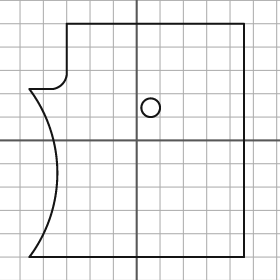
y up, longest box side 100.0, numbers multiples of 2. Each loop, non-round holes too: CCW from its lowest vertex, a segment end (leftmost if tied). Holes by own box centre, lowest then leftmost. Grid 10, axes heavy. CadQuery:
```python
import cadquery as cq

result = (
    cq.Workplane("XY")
    .moveTo(-46.0, -50.0)
    .lineTo(46.0, -50.0)
    .lineTo(46.0, 50.0)
    .lineTo(-30.0, 50.0)
    .lineTo(-30.0, 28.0)
    .threePointArc((-32.0, 24.0), (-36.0, 22.0))
    .lineTo(-46.0, 22.0)
    .threePointArc((-34.0, -14.0), (-46.0, -50.0))
    .close()
    .moveTo(6.0, 14.0)
    .circle(4.0)
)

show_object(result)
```